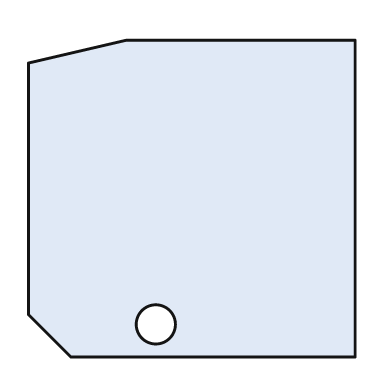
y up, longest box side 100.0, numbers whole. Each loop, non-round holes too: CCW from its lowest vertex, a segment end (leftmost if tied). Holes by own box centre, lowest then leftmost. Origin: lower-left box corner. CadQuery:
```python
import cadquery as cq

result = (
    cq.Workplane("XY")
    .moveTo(13.0, 0.0)
    .lineTo(100.0, 0.0)
    .lineTo(100.0, 97.0)
    .lineTo(30.0, 97.0)
    .lineTo(0.0, 90.0)
    .lineTo(0.0, 13.0)
    .close()
    .moveTo(39.0, 10.0)
    .circle(6.0)
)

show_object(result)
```